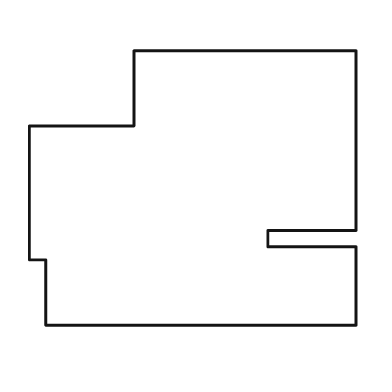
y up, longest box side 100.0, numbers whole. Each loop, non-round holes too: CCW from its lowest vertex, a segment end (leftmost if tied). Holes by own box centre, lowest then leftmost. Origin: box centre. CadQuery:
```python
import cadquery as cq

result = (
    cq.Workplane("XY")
    .moveTo(-45.0, -42.0)
    .lineTo(50.0, -42.0)
    .lineTo(50.0, -18.0)
    .lineTo(23.0, -18.0)
    .lineTo(23.0, -13.0)
    .lineTo(50.0, -13.0)
    .lineTo(50.0, 42.0)
    .lineTo(-18.0, 42.0)
    .lineTo(-18.0, 19.0)
    .lineTo(-50.0, 19.0)
    .lineTo(-50.0, -22.0)
    .lineTo(-45.0, -22.0)
    .close()
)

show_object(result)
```